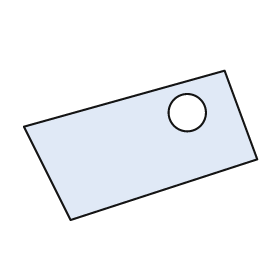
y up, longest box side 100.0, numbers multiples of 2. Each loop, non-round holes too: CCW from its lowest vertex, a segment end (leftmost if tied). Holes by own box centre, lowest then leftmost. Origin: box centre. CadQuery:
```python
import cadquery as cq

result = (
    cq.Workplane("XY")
    .moveTo(-30.0, -32.0)
    .lineTo(50.0, -6.0)
    .lineTo(36.0, 32.0)
    .lineTo(-50.0, 8.0)
    .close()
    .moveTo(20.0, 14.0)
    .circle(8.0)
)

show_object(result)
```